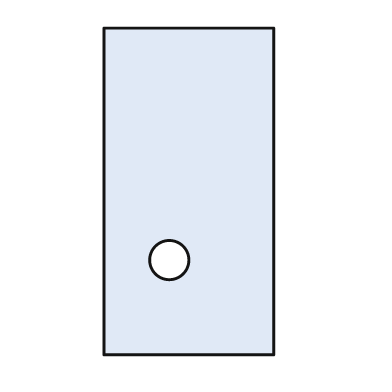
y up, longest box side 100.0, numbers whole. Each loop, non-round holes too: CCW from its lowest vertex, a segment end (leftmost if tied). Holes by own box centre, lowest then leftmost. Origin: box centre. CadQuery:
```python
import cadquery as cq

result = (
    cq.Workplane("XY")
    .moveTo(-26.0, -50.0)
    .lineTo(26.0, -50.0)
    .lineTo(26.0, 50.0)
    .lineTo(-26.0, 50.0)
    .close()
    .moveTo(-6.0, -21.0)
    .circle(6.0)
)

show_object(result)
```